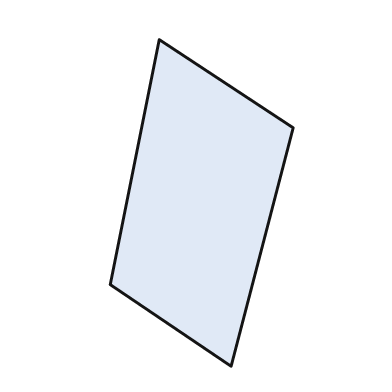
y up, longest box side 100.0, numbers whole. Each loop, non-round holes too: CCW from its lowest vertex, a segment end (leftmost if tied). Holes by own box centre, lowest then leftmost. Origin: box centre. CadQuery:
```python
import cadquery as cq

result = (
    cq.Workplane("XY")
    .moveTo(9.0, -50.0)
    .lineTo(28.0, 23.0)
    .lineTo(-13.0, 50.0)
    .lineTo(-28.0, -25.0)
    .close()
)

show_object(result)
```